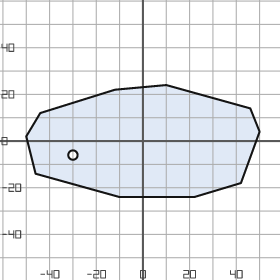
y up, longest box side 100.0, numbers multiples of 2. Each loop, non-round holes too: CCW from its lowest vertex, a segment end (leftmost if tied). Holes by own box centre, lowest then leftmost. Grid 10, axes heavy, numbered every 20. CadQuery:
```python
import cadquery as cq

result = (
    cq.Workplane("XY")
    .moveTo(-10.0, -24.0)
    .lineTo(22.0, -24.0)
    .lineTo(42.0, -18.0)
    .lineTo(50.0, 4.0)
    .lineTo(46.0, 14.0)
    .lineTo(10.0, 24.0)
    .lineTo(-12.0, 22.0)
    .lineTo(-44.0, 12.0)
    .lineTo(-50.0, 2.0)
    .lineTo(-46.0, -14.0)
    .close()
    .moveTo(-30.0, -6.0)
    .circle(2.0)
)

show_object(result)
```